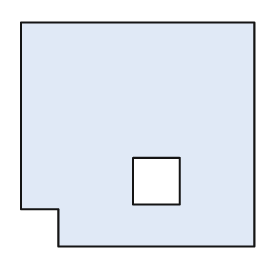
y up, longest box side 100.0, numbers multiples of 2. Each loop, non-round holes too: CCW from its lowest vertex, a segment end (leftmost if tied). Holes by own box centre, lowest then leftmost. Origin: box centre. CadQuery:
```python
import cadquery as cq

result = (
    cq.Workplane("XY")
    .moveTo(-34.0, -48.0)
    .lineTo(50.0, -48.0)
    .lineTo(50.0, 48.0)
    .lineTo(-50.0, 48.0)
    .lineTo(-50.0, -32.0)
    .lineTo(-34.0, -32.0)
    .close()
    .moveTo(-2.0, -30.0)
    .lineTo(18.0, -30.0)
    .lineTo(18.0, -10.0)
    .lineTo(-2.0, -10.0)
    .close()
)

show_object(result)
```